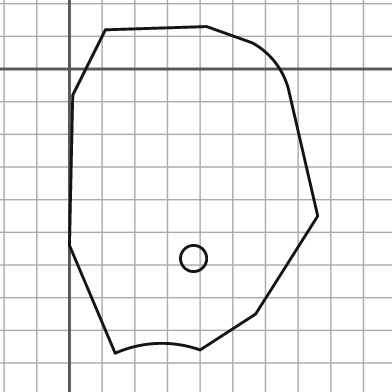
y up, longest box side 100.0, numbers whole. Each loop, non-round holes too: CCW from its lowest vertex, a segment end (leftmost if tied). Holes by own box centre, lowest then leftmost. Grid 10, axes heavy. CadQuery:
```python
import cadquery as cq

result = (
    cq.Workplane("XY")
    .moveTo(14.0, -87.0)
    .threePointArc((27.0, -84.0), (40.0, -86.0))
    .lineTo(57.0, -75.0)
    .lineTo(76.0, -45.0)
    .lineTo(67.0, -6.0)
    .threePointArc((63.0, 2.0), (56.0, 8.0))
    .lineTo(42.0, 13.0)
    .lineTo(11.0, 12.0)
    .lineTo(1.0, -8.0)
    .lineTo(0.0, -54.0)
    .close()
    .moveTo(38.0, -58.0)
    .circle(4.0)
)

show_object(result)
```